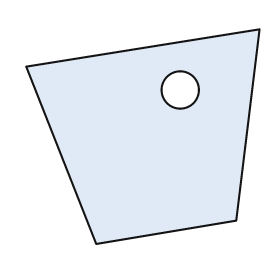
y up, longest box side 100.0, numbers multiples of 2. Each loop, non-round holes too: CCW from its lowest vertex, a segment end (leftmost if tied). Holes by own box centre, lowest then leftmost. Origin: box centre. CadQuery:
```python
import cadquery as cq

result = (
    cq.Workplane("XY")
    .moveTo(-20.0, -46.0)
    .lineTo(40.0, -36.0)
    .lineTo(50.0, 46.0)
    .lineTo(-50.0, 30.0)
    .close()
    .moveTo(16.0, 20.0)
    .circle(8.0)
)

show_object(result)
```